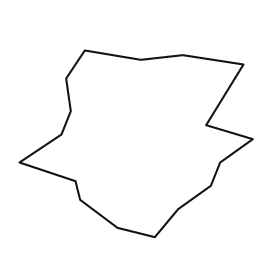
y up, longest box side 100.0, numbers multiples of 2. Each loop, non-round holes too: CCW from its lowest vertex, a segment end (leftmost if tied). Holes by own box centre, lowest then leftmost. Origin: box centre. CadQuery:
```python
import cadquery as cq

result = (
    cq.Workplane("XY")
    .moveTo(8.0, -40.0)
    .lineTo(18.0, -28.0)
    .lineTo(32.0, -18.0)
    .lineTo(36.0, -8.0)
    .lineTo(50.0, 2.0)
    .lineTo(30.0, 8.0)
    .lineTo(46.0, 34.0)
    .lineTo(20.0, 38.0)
    .lineTo(2.0, 36.0)
    .lineTo(-22.0, 40.0)
    .lineTo(-30.0, 28.0)
    .lineTo(-28.0, 14.0)
    .lineTo(-32.0, 4.0)
    .lineTo(-50.0, -8.0)
    .lineTo(-26.0, -16.0)
    .lineTo(-24.0, -24.0)
    .lineTo(-8.0, -36.0)
    .close()
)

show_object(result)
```